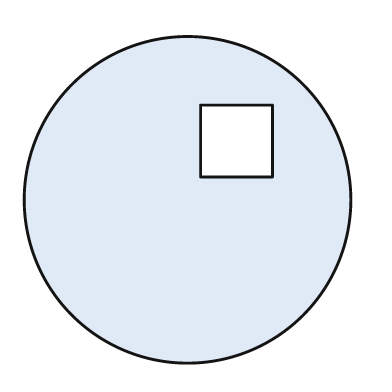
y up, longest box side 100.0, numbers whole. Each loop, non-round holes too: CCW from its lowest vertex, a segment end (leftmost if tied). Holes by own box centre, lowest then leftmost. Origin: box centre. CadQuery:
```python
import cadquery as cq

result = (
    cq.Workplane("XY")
    .moveTo(0.0, 0.0)
    .circle(50.0)
    .moveTo(4.0, 7.0)
    .lineTo(26.0, 7.0)
    .lineTo(26.0, 29.0)
    .lineTo(4.0, 29.0)
    .close()
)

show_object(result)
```